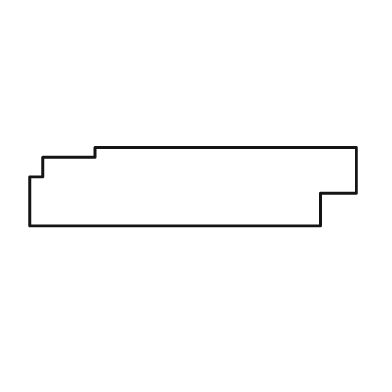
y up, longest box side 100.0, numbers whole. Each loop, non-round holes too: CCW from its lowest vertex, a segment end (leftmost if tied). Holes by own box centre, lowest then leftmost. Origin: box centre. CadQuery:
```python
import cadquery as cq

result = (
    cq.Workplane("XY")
    .moveTo(-50.0, -12.0)
    .lineTo(39.0, -12.0)
    .lineTo(39.0, -2.0)
    .lineTo(50.0, -2.0)
    .lineTo(50.0, 12.0)
    .lineTo(-30.0, 12.0)
    .lineTo(-30.0, 9.0)
    .lineTo(-46.0, 9.0)
    .lineTo(-46.0, 3.0)
    .lineTo(-50.0, 3.0)
    .close()
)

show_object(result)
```